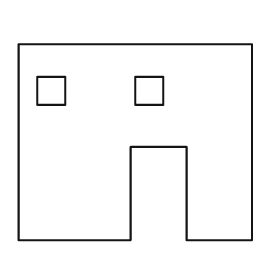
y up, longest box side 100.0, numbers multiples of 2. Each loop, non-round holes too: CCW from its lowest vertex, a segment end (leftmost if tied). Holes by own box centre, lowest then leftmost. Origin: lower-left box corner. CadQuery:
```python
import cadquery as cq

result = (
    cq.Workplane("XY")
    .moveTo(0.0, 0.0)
    .lineTo(48.0, 0.0)
    .lineTo(48.0, 40.0)
    .lineTo(72.0, 40.0)
    .lineTo(72.0, 0.0)
    .lineTo(100.0, 0.0)
    .lineTo(100.0, 84.0)
    .lineTo(0.0, 84.0)
    .close()
    .moveTo(8.0, 58.0)
    .lineTo(20.0, 58.0)
    .lineTo(20.0, 70.0)
    .lineTo(8.0, 70.0)
    .close()
    .moveTo(50.0, 58.0)
    .lineTo(62.0, 58.0)
    .lineTo(62.0, 70.0)
    .lineTo(50.0, 70.0)
    .close()
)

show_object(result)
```